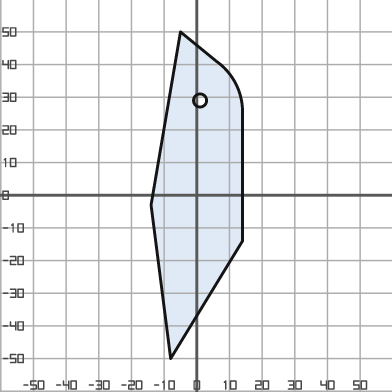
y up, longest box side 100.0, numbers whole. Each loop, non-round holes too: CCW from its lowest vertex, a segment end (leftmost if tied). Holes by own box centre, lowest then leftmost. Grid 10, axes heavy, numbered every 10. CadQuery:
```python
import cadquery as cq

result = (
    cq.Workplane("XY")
    .moveTo(-8.0, -50.0)
    .lineTo(14.0, -14.0)
    .lineTo(14.0, 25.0)
    .threePointArc((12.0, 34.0), (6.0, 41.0))
    .lineTo(-5.0, 50.0)
    .lineTo(-14.0, -3.0)
    .close()
    .moveTo(1.0, 29.0)
    .circle(2.0)
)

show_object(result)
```